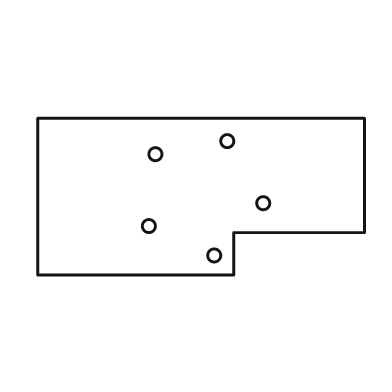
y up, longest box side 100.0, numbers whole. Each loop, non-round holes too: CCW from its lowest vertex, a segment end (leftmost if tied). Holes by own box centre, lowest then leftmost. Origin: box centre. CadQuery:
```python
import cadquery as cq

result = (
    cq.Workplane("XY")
    .moveTo(-50.0, -24.0)
    .lineTo(10.0, -24.0)
    .lineTo(10.0, -11.0)
    .lineTo(50.0, -11.0)
    .lineTo(50.0, 24.0)
    .lineTo(-50.0, 24.0)
    .close()
    .moveTo(4.0, -18.0)
    .circle(2.0)
    .moveTo(-16.0, -9.0)
    .circle(2.0)
    .moveTo(19.0, -2.0)
    .circle(2.0)
    .moveTo(-14.0, 13.0)
    .circle(2.0)
    .moveTo(8.0, 17.0)
    .circle(2.0)
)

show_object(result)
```